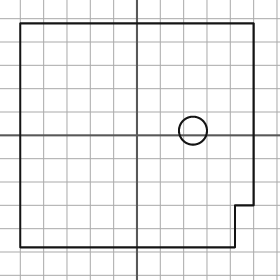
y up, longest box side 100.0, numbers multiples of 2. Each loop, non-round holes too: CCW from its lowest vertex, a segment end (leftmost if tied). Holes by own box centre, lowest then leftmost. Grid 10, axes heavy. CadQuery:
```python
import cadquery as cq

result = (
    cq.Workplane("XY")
    .moveTo(-50.0, -48.0)
    .lineTo(42.0, -48.0)
    .lineTo(42.0, -30.0)
    .lineTo(50.0, -30.0)
    .lineTo(50.0, 48.0)
    .lineTo(-50.0, 48.0)
    .close()
    .moveTo(24.0, 2.0)
    .circle(6.0)
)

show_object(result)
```